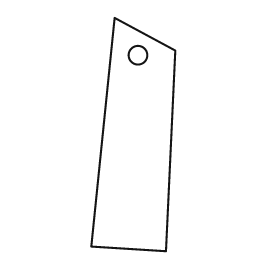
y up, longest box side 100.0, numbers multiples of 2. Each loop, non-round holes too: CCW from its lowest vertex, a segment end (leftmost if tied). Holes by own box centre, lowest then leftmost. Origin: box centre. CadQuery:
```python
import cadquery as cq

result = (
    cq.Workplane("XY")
    .moveTo(14.0, -50.0)
    .lineTo(18.0, 36.0)
    .lineTo(-8.0, 50.0)
    .lineTo(-18.0, -48.0)
    .close()
    .moveTo(2.0, 34.0)
    .circle(4.0)
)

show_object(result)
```